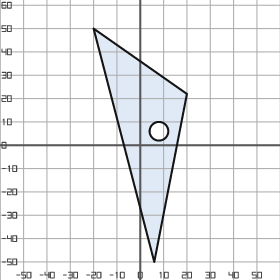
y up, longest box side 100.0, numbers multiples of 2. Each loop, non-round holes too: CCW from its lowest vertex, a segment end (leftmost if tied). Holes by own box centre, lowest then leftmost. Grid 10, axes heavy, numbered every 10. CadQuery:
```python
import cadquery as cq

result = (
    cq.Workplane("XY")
    .moveTo(6.0, -50.0)
    .lineTo(20.0, 22.0)
    .lineTo(-20.0, 50.0)
    .close()
    .moveTo(8.0, 6.0)
    .circle(4.0)
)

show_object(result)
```